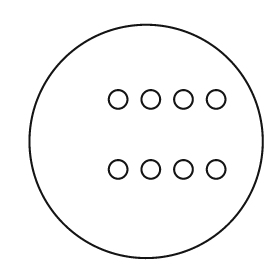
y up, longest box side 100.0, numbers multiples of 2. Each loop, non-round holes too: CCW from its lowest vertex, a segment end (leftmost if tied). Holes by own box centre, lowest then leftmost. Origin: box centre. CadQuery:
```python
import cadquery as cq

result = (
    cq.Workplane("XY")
    .moveTo(0.0, 0.0)
    .circle(50.0)
    .moveTo(-12.0, -12.0)
    .circle(4.0)
    .moveTo(2.0, -12.0)
    .circle(4.0)
    .moveTo(16.0, -12.0)
    .circle(4.0)
    .moveTo(30.0, -12.0)
    .circle(4.0)
    .moveTo(-12.0, 18.0)
    .circle(4.0)
    .moveTo(2.0, 18.0)
    .circle(4.0)
    .moveTo(16.0, 18.0)
    .circle(4.0)
    .moveTo(30.0, 18.0)
    .circle(4.0)
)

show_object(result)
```